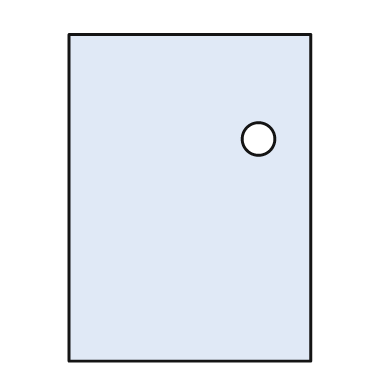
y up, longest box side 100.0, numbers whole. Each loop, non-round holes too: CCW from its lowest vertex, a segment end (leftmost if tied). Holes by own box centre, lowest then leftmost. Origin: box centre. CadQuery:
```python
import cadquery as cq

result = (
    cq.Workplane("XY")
    .moveTo(-37.0, -50.0)
    .lineTo(37.0, -50.0)
    .lineTo(37.0, 50.0)
    .lineTo(-37.0, 50.0)
    .close()
    .moveTo(21.0, 18.0)
    .circle(5.0)
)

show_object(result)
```